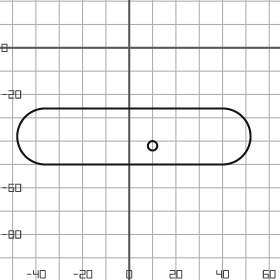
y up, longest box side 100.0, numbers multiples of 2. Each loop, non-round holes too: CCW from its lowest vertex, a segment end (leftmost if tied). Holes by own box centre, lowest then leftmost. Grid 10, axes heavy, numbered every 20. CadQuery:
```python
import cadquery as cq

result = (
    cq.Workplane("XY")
    .moveTo(-36.0, -50.0)
    .lineTo(40.0, -50.0)
    .threePointArc((52.0, -38.0), (40.0, -26.0))
    .lineTo(-36.0, -26.0)
    .threePointArc((-48.0, -38.0), (-36.0, -50.0))
    .close()
    .moveTo(10.0, -42.0)
    .circle(2.0)
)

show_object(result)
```